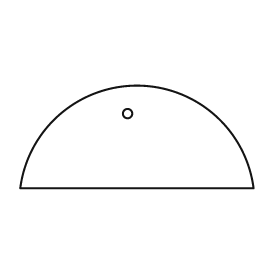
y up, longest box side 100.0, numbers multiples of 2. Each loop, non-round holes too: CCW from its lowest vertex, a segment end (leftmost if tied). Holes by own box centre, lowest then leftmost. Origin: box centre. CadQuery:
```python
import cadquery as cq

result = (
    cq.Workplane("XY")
    .moveTo(-50.0, -22.0)
    .lineTo(50.0, -22.0)
    .threePointArc((0.0, 22.0), (-50.0, -22.0))
    .close()
    .moveTo(-4.0, 10.0)
    .circle(2.0)
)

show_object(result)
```